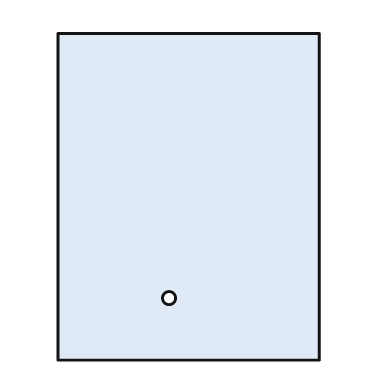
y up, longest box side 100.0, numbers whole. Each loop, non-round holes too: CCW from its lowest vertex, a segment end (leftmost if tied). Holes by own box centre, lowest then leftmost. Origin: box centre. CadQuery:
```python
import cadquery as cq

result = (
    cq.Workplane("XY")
    .moveTo(-40.0, -50.0)
    .lineTo(40.0, -50.0)
    .lineTo(40.0, 50.0)
    .lineTo(-40.0, 50.0)
    .close()
    .moveTo(-6.0, -31.0)
    .circle(2.0)
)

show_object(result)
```